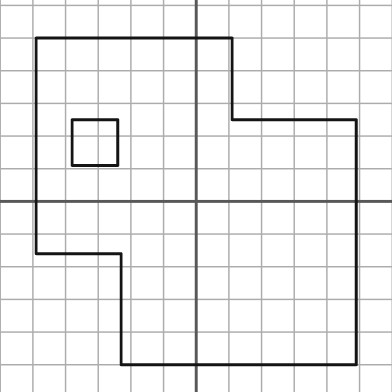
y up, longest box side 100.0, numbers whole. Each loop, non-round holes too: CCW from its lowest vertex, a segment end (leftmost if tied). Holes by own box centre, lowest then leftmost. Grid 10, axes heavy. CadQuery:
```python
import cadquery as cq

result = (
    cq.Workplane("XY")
    .moveTo(-23.0, -50.0)
    .lineTo(49.0, -50.0)
    .lineTo(49.0, 25.0)
    .lineTo(11.0, 25.0)
    .lineTo(11.0, 50.0)
    .lineTo(-49.0, 50.0)
    .lineTo(-49.0, -16.0)
    .lineTo(-23.0, -16.0)
    .close()
    .moveTo(-38.0, 11.0)
    .lineTo(-24.0, 11.0)
    .lineTo(-24.0, 25.0)
    .lineTo(-38.0, 25.0)
    .close()
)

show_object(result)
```